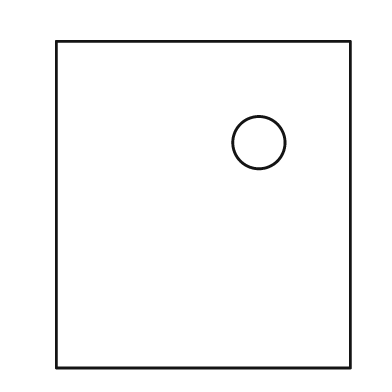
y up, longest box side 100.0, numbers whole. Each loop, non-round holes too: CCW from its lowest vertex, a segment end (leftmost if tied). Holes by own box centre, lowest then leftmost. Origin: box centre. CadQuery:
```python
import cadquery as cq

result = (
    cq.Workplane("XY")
    .moveTo(-45.0, -50.0)
    .lineTo(45.0, -50.0)
    .lineTo(45.0, 50.0)
    .lineTo(-45.0, 50.0)
    .close()
    .moveTo(17.0, 19.0)
    .circle(8.0)
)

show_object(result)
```